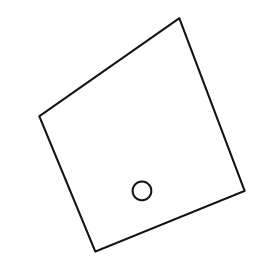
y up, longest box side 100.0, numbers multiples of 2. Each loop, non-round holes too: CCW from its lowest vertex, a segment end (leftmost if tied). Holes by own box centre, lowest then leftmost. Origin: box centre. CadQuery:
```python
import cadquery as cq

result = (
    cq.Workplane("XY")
    .moveTo(-20.0, -50.0)
    .lineTo(44.0, -24.0)
    .lineTo(16.0, 50.0)
    .lineTo(-44.0, 8.0)
    .close()
    .moveTo(0.0, -24.0)
    .circle(4.0)
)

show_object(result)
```